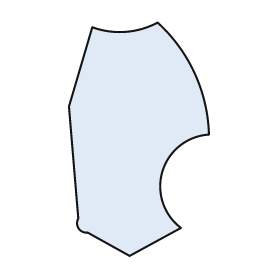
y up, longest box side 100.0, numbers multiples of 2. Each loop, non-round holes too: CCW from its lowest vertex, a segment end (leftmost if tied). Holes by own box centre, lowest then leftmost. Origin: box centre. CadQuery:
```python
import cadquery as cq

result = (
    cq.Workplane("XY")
    .moveTo(-4.0, -50.0)
    .lineTo(18.0, -38.0)
    .threePointArc((10.0, -14.0), (30.0, 2.0))
    .threePointArc((24.0, 28.0), (8.0, 50.0))
    .threePointArc((-6.0, 46.0), (-20.0, 48.0))
    .lineTo(-30.0, 14.0)
    .lineTo(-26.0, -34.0)
    .threePointArc((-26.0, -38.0), (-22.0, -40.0))
    .close()
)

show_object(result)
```